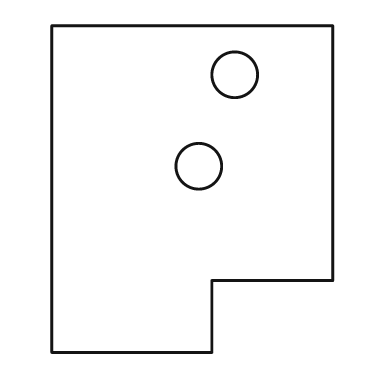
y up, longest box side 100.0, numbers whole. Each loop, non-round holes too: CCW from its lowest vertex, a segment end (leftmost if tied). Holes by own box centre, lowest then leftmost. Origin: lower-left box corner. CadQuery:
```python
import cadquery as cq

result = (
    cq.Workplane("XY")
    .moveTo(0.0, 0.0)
    .lineTo(49.0, 0.0)
    .lineTo(49.0, 22.0)
    .lineTo(86.0, 22.0)
    .lineTo(86.0, 100.0)
    .lineTo(0.0, 100.0)
    .close()
    .moveTo(45.0, 57.0)
    .circle(7.0)
    .moveTo(56.0, 85.0)
    .circle(7.0)
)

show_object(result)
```